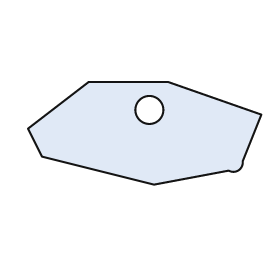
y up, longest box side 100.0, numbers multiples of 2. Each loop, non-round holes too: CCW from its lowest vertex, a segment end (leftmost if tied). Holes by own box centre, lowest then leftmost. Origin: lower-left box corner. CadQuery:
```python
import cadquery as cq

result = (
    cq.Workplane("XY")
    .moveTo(54.0, 0.0)
    .lineTo(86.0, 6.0)
    .threePointArc((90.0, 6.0), (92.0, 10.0))
    .lineTo(100.0, 30.0)
    .lineTo(60.0, 44.0)
    .lineTo(26.0, 44.0)
    .lineTo(0.0, 24.0)
    .lineTo(6.0, 12.0)
    .close()
    .moveTo(52.0, 32.0)
    .circle(6.0)
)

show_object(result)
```